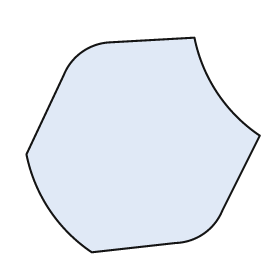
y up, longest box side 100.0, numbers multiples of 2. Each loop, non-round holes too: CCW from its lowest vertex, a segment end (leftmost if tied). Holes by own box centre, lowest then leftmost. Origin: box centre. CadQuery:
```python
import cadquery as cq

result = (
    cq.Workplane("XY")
    .moveTo(-22.0, -46.0)
    .lineTo(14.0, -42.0)
    .threePointArc((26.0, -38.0), (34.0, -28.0))
    .lineTo(50.0, 4.0)
    .threePointArc((32.0, 22.0), (22.0, 46.0))
    .lineTo(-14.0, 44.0)
    .threePointArc((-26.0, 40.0), (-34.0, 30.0))
    .lineTo(-50.0, -4.0)
    .threePointArc((-40.0, -28.0), (-22.0, -46.0))
    .close()
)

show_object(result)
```